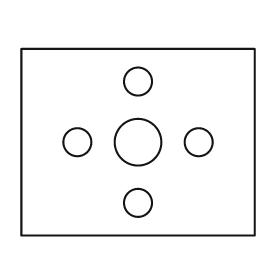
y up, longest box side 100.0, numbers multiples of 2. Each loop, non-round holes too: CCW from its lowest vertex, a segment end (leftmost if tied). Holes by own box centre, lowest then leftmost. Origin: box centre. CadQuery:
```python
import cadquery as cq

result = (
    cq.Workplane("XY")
    .moveTo(-50.0, -40.0)
    .lineTo(50.0, -40.0)
    .lineTo(50.0, 40.0)
    .lineTo(-50.0, 40.0)
    .close()
    .moveTo(0.0, -26.0)
    .circle(6.0)
    .moveTo(-26.0, 0.0)
    .circle(6.0)
    .moveTo(0.0, 0.0)
    .circle(10.0)
    .moveTo(26.0, 0.0)
    .circle(6.0)
    .moveTo(0.0, 26.0)
    .circle(6.0)
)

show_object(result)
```